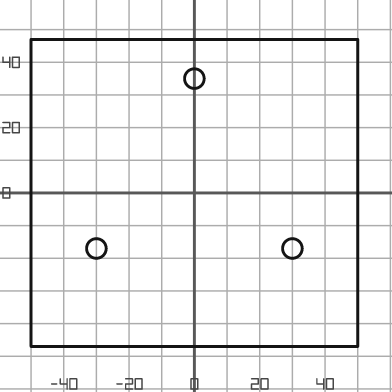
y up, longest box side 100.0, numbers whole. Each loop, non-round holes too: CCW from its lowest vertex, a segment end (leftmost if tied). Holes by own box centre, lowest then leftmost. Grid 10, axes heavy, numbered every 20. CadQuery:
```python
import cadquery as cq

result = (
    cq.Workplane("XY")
    .moveTo(-50.0, -47.0)
    .lineTo(50.0, -47.0)
    .lineTo(50.0, 47.0)
    .lineTo(-50.0, 47.0)
    .close()
    .moveTo(-30.0, -17.0)
    .circle(3.0)
    .moveTo(30.0, -17.0)
    .circle(3.0)
    .moveTo(0.0, 35.0)
    .circle(3.0)
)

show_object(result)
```